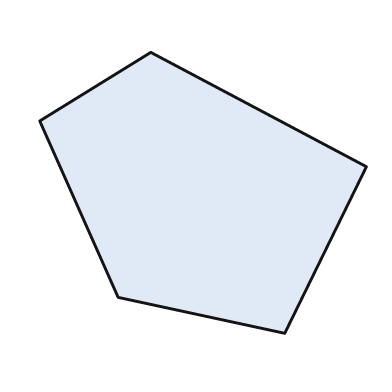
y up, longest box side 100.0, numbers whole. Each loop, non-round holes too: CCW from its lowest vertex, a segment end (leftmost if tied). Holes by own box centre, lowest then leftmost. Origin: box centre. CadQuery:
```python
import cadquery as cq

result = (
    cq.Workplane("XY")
    .moveTo(25.0, -43.0)
    .lineTo(50.0, 8.0)
    .lineTo(-16.0, 43.0)
    .lineTo(-50.0, 22.0)
    .lineTo(-26.0, -32.0)
    .close()
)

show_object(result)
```